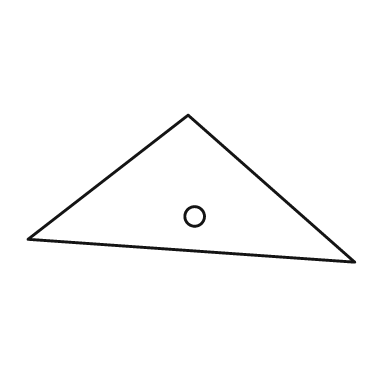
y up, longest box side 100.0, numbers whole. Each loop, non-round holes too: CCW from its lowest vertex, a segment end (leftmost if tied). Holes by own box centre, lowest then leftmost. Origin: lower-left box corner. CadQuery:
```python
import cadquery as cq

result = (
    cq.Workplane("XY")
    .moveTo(100.0, 0.0)
    .lineTo(49.0, 45.0)
    .lineTo(0.0, 7.0)
    .close()
    .moveTo(51.0, 14.0)
    .circle(3.0)
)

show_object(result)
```